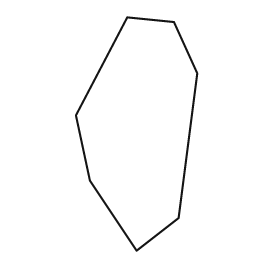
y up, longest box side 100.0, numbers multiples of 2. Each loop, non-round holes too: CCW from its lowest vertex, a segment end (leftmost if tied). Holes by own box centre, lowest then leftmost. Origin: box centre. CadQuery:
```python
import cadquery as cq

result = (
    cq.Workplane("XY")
    .moveTo(0.0, -50.0)
    .lineTo(18.0, -36.0)
    .lineTo(26.0, 26.0)
    .lineTo(16.0, 48.0)
    .lineTo(-4.0, 50.0)
    .lineTo(-26.0, 8.0)
    .lineTo(-20.0, -20.0)
    .close()
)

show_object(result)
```